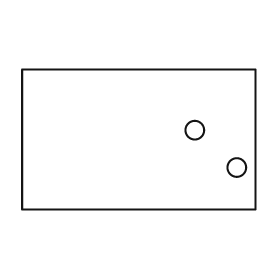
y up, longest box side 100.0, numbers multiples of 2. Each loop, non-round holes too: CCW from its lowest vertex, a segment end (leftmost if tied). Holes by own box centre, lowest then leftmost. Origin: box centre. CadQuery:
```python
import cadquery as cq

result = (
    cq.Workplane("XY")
    .moveTo(-50.0, -30.0)
    .lineTo(50.0, -30.0)
    .lineTo(50.0, 30.0)
    .lineTo(-50.0, 30.0)
    .close()
    .moveTo(42.0, -12.0)
    .circle(4.0)
    .moveTo(24.0, 4.0)
    .circle(4.0)
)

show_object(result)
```